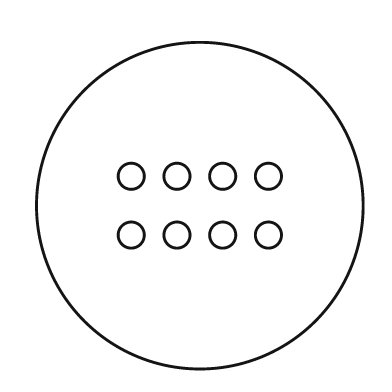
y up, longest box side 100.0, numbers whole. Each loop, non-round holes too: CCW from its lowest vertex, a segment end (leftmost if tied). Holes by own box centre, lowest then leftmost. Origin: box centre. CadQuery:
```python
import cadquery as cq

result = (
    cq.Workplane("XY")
    .moveTo(0.0, 0.0)
    .circle(50.0)
    .moveTo(-21.0, -9.0)
    .circle(4.0)
    .moveTo(-7.0, -9.0)
    .circle(4.0)
    .moveTo(7.0, -9.0)
    .circle(4.0)
    .moveTo(21.0, -9.0)
    .circle(4.0)
    .moveTo(-21.0, 9.0)
    .circle(4.0)
    .moveTo(-7.0, 9.0)
    .circle(4.0)
    .moveTo(7.0, 9.0)
    .circle(4.0)
    .moveTo(21.0, 9.0)
    .circle(4.0)
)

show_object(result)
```